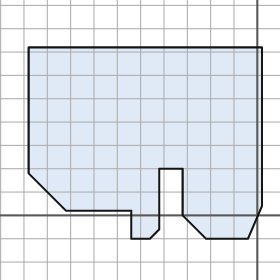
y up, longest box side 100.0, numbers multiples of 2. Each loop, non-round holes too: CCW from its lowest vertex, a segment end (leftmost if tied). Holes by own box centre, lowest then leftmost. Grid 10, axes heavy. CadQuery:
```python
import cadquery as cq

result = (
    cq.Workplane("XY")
    .moveTo(-54.0, -10.0)
    .lineTo(-46.0, -10.0)
    .lineTo(-42.0, -6.0)
    .lineTo(-42.0, 20.0)
    .lineTo(-32.0, 20.0)
    .lineTo(-32.0, 0.0)
    .lineTo(-22.0, -10.0)
    .lineTo(-4.0, -10.0)
    .lineTo(2.0, 4.0)
    .lineTo(2.0, 72.0)
    .lineTo(-98.0, 72.0)
    .lineTo(-98.0, 18.0)
    .lineTo(-82.0, 2.0)
    .lineTo(-54.0, 2.0)
    .close()
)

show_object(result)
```